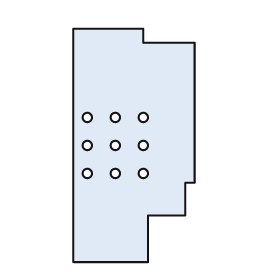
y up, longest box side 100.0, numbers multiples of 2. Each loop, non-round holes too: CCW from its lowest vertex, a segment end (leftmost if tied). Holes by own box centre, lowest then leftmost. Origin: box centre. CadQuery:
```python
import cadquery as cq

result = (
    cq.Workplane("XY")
    .moveTo(-26.0, -50.0)
    .lineTo(6.0, -50.0)
    .lineTo(6.0, -30.0)
    .lineTo(22.0, -30.0)
    .lineTo(22.0, -16.0)
    .lineTo(26.0, -16.0)
    .lineTo(26.0, 44.0)
    .lineTo(4.0, 44.0)
    .lineTo(4.0, 50.0)
    .lineTo(-26.0, 50.0)
    .close()
    .moveTo(-20.0, -12.0)
    .circle(2.0)
    .moveTo(-8.0, -12.0)
    .circle(2.0)
    .moveTo(4.0, -12.0)
    .circle(2.0)
    .moveTo(-20.0, 0.0)
    .circle(2.0)
    .moveTo(-8.0, 0.0)
    .circle(2.0)
    .moveTo(4.0, 0.0)
    .circle(2.0)
    .moveTo(-20.0, 12.0)
    .circle(2.0)
    .moveTo(-8.0, 12.0)
    .circle(2.0)
    .moveTo(4.0, 12.0)
    .circle(2.0)
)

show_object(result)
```